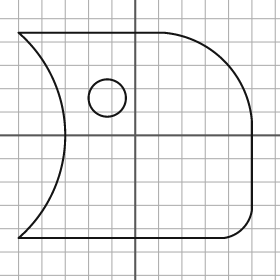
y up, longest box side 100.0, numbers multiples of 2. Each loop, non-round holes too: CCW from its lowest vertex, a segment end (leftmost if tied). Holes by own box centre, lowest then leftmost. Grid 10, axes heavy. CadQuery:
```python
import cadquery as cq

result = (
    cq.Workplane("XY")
    .moveTo(-50.0, -44.0)
    .lineTo(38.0, -44.0)
    .threePointArc((46.0, -40.0), (50.0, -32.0))
    .lineTo(50.0, 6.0)
    .threePointArc((38.0, 32.0), (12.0, 44.0))
    .lineTo(-50.0, 44.0)
    .threePointArc((-30.0, 0.0), (-50.0, -44.0))
    .close()
    .moveTo(-12.0, 16.0)
    .circle(8.0)
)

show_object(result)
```